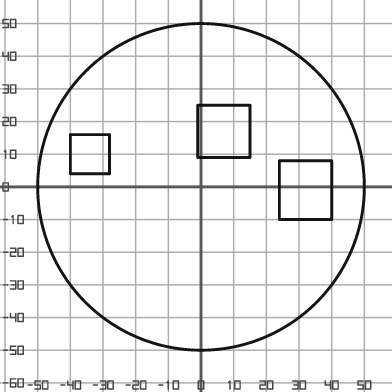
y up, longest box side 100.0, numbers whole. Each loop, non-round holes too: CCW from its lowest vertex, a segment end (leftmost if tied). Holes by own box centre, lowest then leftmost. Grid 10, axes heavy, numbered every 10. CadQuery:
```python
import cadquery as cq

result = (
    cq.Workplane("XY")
    .moveTo(0.0, 0.0)
    .circle(50.0)
    .moveTo(24.0, -10.0)
    .lineTo(40.0, -10.0)
    .lineTo(40.0, 8.0)
    .lineTo(24.0, 8.0)
    .close()
    .moveTo(-40.0, 4.0)
    .lineTo(-28.0, 4.0)
    .lineTo(-28.0, 16.0)
    .lineTo(-40.0, 16.0)
    .close()
    .moveTo(-1.0, 9.0)
    .lineTo(15.0, 9.0)
    .lineTo(15.0, 25.0)
    .lineTo(-1.0, 25.0)
    .close()
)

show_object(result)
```